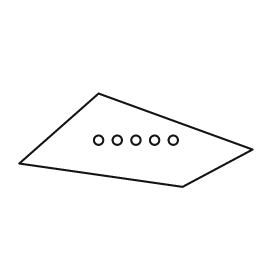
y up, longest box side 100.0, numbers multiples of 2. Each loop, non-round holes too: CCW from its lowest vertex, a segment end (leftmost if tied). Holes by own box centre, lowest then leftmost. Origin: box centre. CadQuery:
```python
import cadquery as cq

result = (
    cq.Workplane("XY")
    .moveTo(20.0, -20.0)
    .lineTo(50.0, -4.0)
    .lineTo(-16.0, 20.0)
    .lineTo(-50.0, -10.0)
    .close()
    .moveTo(-16.0, 0.0)
    .circle(2.0)
    .moveTo(-8.0, 0.0)
    .circle(2.0)
    .moveTo(0.0, 0.0)
    .circle(2.0)
    .moveTo(8.0, 0.0)
    .circle(2.0)
    .moveTo(16.0, 0.0)
    .circle(2.0)
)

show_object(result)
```